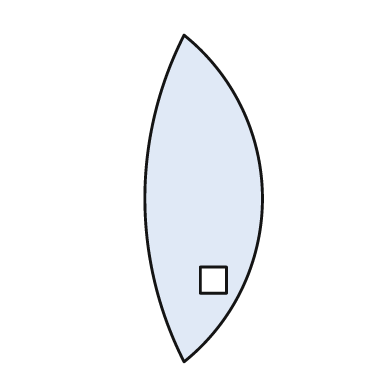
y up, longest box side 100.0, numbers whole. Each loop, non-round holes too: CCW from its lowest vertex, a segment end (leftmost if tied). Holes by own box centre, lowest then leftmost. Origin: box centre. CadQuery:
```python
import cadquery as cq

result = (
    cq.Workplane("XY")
    .moveTo(-6.0, -50.0)
    .threePointArc((18.0, 0.0), (-6.0, 50.0))
    .threePointArc((-18.0, 0.0), (-6.0, -50.0))
    .close()
    .moveTo(-1.0, -29.0)
    .lineTo(7.0, -29.0)
    .lineTo(7.0, -21.0)
    .lineTo(-1.0, -21.0)
    .close()
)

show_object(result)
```